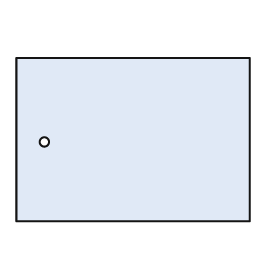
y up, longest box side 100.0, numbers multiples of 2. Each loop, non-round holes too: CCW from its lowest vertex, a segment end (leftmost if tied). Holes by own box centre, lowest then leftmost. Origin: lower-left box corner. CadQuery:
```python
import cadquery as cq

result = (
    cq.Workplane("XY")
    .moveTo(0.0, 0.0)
    .lineTo(100.0, 0.0)
    .lineTo(100.0, 70.0)
    .lineTo(0.0, 70.0)
    .close()
    .moveTo(12.0, 34.0)
    .circle(2.0)
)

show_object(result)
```